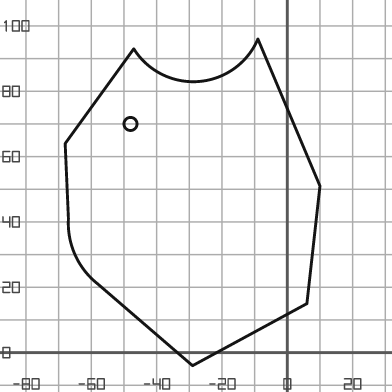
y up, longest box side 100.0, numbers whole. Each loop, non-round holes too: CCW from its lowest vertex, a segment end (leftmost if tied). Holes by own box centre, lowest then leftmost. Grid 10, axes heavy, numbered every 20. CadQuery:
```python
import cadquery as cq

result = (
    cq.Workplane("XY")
    .moveTo(-29.0, -4.0)
    .lineTo(6.0, 15.0)
    .lineTo(10.0, 51.0)
    .lineTo(-9.0, 96.0)
    .threePointArc((-27.0, 83.0), (-47.0, 93.0))
    .lineTo(-68.0, 64.0)
    .lineTo(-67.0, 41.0)
    .threePointArc((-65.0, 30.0), (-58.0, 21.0))
    .close()
    .moveTo(-48.0, 70.0)
    .circle(2.0)
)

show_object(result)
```